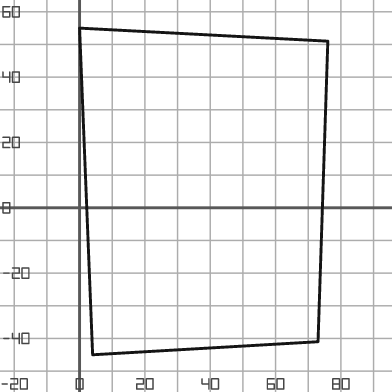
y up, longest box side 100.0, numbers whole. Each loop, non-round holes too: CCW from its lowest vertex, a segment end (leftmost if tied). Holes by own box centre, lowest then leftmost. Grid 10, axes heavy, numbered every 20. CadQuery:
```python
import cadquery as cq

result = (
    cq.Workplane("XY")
    .moveTo(4.0, -45.0)
    .lineTo(73.0, -41.0)
    .lineTo(76.0, 51.0)
    .lineTo(0.0, 55.0)
    .close()
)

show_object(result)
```